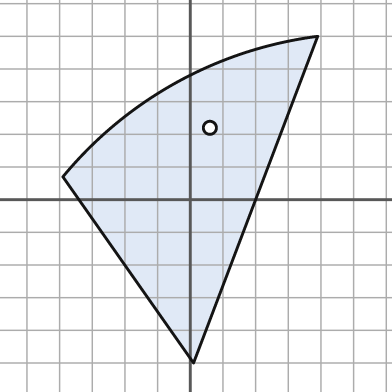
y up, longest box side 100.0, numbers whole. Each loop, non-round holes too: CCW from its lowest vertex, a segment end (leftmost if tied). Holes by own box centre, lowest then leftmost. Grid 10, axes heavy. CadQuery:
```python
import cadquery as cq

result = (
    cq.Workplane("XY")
    .moveTo(1.0, -50.0)
    .lineTo(39.0, 50.0)
    .threePointArc((-4.0, 36.0), (-39.0, 7.0))
    .close()
    .moveTo(6.0, 22.0)
    .circle(2.0)
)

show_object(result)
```